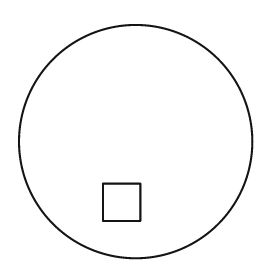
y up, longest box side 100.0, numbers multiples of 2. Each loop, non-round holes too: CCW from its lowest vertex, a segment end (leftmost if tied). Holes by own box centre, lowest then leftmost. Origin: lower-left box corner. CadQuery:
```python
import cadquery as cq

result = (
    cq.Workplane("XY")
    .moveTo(50.0, 50.0)
    .circle(50.0)
    .moveTo(36.0, 16.0)
    .lineTo(52.0, 16.0)
    .lineTo(52.0, 32.0)
    .lineTo(36.0, 32.0)
    .close()
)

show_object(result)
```